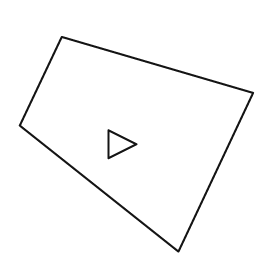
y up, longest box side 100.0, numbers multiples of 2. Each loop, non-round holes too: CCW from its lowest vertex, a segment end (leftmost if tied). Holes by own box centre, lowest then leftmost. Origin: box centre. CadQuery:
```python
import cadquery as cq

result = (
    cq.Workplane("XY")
    .moveTo(18.0, -46.0)
    .lineTo(50.0, 22.0)
    .lineTo(-32.0, 46.0)
    .lineTo(-50.0, 8.0)
    .close()
    .moveTo(-12.0, -6.0)
    .lineTo(0.0, 0.0)
    .lineTo(-12.0, 6.0)
    .close()
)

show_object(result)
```